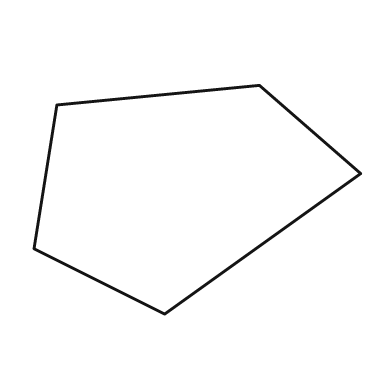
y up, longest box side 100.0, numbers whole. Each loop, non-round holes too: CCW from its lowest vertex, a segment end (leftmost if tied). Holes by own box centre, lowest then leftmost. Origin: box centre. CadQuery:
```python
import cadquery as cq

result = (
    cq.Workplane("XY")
    .moveTo(-10.0, -35.0)
    .lineTo(50.0, 8.0)
    .lineTo(19.0, 35.0)
    .lineTo(-43.0, 29.0)
    .lineTo(-50.0, -15.0)
    .close()
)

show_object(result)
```